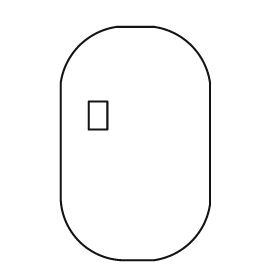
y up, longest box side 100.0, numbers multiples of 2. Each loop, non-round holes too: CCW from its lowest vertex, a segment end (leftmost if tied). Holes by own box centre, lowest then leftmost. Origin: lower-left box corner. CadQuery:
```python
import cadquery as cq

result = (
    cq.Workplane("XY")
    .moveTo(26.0, 0.0)
    .lineTo(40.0, 0.0)
    .threePointArc((56.0, 8.0), (64.0, 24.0))
    .lineTo(64.0, 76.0)
    .threePointArc((56.0, 92.0), (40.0, 100.0))
    .lineTo(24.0, 100.0)
    .threePointArc((8.0, 92.0), (0.0, 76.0))
    .lineTo(0.0, 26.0)
    .threePointArc((8.0, 8.0), (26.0, 0.0))
    .close()
    .moveTo(12.0, 56.0)
    .lineTo(20.0, 56.0)
    .lineTo(20.0, 68.0)
    .lineTo(12.0, 68.0)
    .close()
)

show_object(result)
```